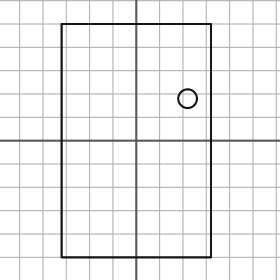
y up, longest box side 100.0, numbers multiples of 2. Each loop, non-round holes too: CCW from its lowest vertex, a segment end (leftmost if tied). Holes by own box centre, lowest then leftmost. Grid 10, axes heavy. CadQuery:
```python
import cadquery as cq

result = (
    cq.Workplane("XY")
    .moveTo(-32.0, -50.0)
    .lineTo(32.0, -50.0)
    .lineTo(32.0, 50.0)
    .lineTo(-32.0, 50.0)
    .close()
    .moveTo(22.0, 18.0)
    .circle(4.0)
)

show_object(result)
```